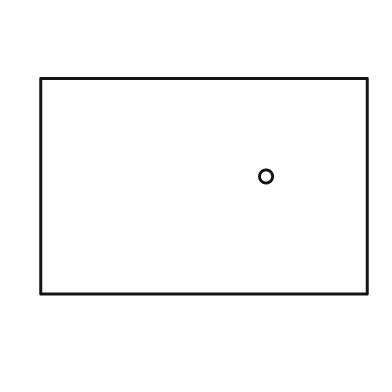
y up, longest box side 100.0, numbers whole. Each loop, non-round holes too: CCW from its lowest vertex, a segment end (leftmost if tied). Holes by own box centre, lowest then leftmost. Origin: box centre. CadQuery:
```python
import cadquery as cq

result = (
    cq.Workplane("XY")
    .moveTo(-50.0, -33.0)
    .lineTo(50.0, -33.0)
    .lineTo(50.0, 33.0)
    .lineTo(-50.0, 33.0)
    .close()
    .moveTo(19.0, 3.0)
    .circle(2.0)
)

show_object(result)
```